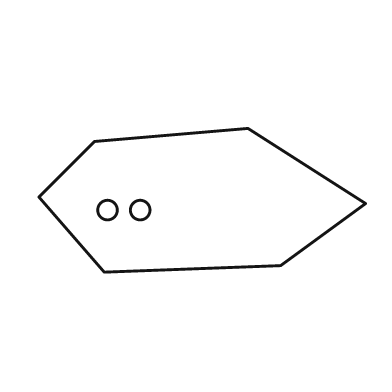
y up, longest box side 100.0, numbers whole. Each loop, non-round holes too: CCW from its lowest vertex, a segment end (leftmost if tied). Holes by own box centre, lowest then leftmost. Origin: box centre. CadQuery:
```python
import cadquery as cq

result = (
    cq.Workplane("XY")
    .moveTo(-30.0, -22.0)
    .lineTo(24.0, -20.0)
    .lineTo(50.0, -1.0)
    .lineTo(14.0, 22.0)
    .lineTo(-33.0, 18.0)
    .lineTo(-50.0, 1.0)
    .close()
    .moveTo(-29.0, -3.0)
    .circle(3.0)
    .moveTo(-19.0, -3.0)
    .circle(3.0)
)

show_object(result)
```